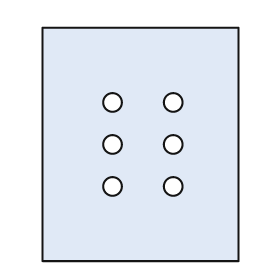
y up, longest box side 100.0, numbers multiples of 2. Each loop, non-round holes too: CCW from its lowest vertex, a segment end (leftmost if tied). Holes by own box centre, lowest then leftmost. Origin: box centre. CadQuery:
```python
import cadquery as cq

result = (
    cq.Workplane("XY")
    .moveTo(-42.0, -50.0)
    .lineTo(42.0, -50.0)
    .lineTo(42.0, 50.0)
    .lineTo(-42.0, 50.0)
    .close()
    .moveTo(-12.0, -18.0)
    .circle(4.0)
    .moveTo(14.0, -18.0)
    .circle(4.0)
    .moveTo(-12.0, 0.0)
    .circle(4.0)
    .moveTo(14.0, 0.0)
    .circle(4.0)
    .moveTo(-12.0, 18.0)
    .circle(4.0)
    .moveTo(14.0, 18.0)
    .circle(4.0)
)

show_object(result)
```